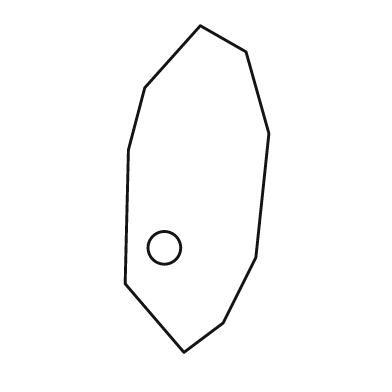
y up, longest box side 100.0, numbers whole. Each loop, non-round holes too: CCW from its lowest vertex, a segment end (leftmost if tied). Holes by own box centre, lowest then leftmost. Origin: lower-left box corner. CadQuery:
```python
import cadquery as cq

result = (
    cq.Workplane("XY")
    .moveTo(18.0, 0.0)
    .lineTo(30.0, 9.0)
    .lineTo(40.0, 29.0)
    .lineTo(44.0, 67.0)
    .lineTo(37.0, 92.0)
    .lineTo(23.0, 100.0)
    .lineTo(6.0, 81.0)
    .lineTo(1.0, 62.0)
    .lineTo(0.0, 21.0)
    .close()
    .moveTo(12.0, 32.0)
    .circle(5.0)
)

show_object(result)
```